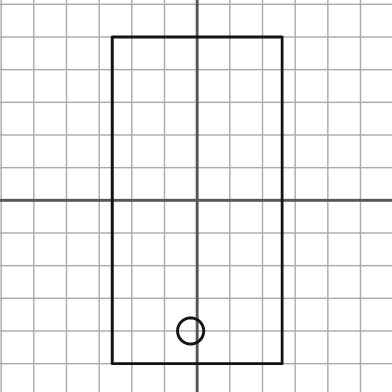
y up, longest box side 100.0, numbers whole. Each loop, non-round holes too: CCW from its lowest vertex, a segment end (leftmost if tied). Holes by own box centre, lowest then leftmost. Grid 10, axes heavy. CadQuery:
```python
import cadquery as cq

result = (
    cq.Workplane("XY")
    .moveTo(-26.0, -50.0)
    .lineTo(26.0, -50.0)
    .lineTo(26.0, 50.0)
    .lineTo(-26.0, 50.0)
    .close()
    .moveTo(-2.0, -40.0)
    .circle(4.0)
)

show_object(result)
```